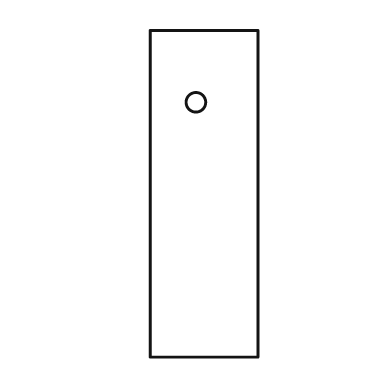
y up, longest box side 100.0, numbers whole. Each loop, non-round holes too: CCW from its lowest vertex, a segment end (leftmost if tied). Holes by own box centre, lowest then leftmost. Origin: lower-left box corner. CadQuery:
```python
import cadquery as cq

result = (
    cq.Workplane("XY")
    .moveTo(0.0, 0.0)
    .lineTo(33.0, 0.0)
    .lineTo(33.0, 100.0)
    .lineTo(0.0, 100.0)
    .close()
    .moveTo(14.0, 78.0)
    .circle(3.0)
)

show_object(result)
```